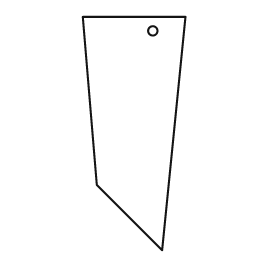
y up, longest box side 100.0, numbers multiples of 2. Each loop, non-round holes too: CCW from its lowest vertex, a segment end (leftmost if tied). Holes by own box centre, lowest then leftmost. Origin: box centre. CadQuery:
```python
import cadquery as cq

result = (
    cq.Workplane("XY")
    .moveTo(12.0, -50.0)
    .lineTo(22.0, 50.0)
    .lineTo(-22.0, 50.0)
    .lineTo(-16.0, -22.0)
    .close()
    .moveTo(8.0, 44.0)
    .circle(2.0)
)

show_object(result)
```